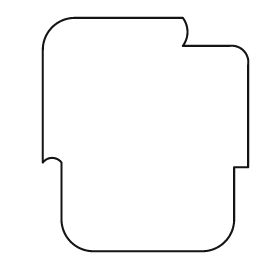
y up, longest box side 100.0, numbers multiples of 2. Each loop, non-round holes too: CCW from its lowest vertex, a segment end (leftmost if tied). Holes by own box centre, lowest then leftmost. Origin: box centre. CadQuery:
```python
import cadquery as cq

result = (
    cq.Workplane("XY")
    .moveTo(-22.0, -50.0)
    .lineTo(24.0, -50.0)
    .threePointArc((34.0, -46.0), (38.0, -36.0))
    .lineTo(38.0, -14.0)
    .lineTo(44.0, -14.0)
    .lineTo(44.0, 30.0)
    .threePointArc((42.0, 36.0), (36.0, 38.0))
    .lineTo(16.0, 38.0)
    .threePointArc((18.0, 44.0), (16.0, 50.0))
    .lineTo(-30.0, 50.0)
    .threePointArc((-40.0, 46.0), (-44.0, 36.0))
    .lineTo(-44.0, -12.0)
    .threePointArc((-40.0, -10.0), (-36.0, -12.0))
    .lineTo(-36.0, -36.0)
    .threePointArc((-32.0, -46.0), (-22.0, -50.0))
    .close()
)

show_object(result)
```